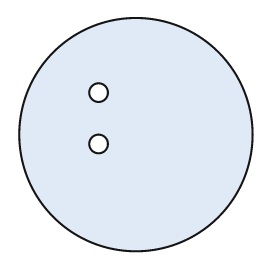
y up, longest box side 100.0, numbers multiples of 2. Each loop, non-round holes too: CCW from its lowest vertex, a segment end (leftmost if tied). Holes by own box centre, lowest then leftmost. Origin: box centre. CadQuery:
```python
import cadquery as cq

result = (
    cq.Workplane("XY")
    .moveTo(0.0, 0.0)
    .circle(50.0)
    .moveTo(-16.0, -4.0)
    .circle(4.0)
    .moveTo(-16.0, 18.0)
    .circle(4.0)
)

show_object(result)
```